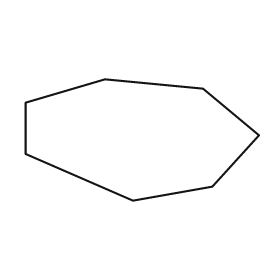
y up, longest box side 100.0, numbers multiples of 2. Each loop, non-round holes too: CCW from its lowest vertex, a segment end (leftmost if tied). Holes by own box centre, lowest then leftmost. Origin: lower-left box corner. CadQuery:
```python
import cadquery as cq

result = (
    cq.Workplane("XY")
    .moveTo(46.0, 0.0)
    .lineTo(80.0, 6.0)
    .lineTo(100.0, 28.0)
    .lineTo(76.0, 48.0)
    .lineTo(34.0, 52.0)
    .lineTo(0.0, 42.0)
    .lineTo(0.0, 20.0)
    .close()
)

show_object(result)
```